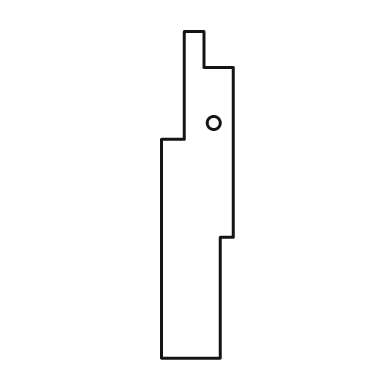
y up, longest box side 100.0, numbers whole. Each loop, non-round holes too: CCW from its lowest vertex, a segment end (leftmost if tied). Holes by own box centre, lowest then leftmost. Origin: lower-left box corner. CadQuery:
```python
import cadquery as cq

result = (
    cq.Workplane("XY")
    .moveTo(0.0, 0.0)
    .lineTo(18.0, 0.0)
    .lineTo(18.0, 37.0)
    .lineTo(22.0, 37.0)
    .lineTo(22.0, 89.0)
    .lineTo(13.0, 89.0)
    .lineTo(13.0, 100.0)
    .lineTo(7.0, 100.0)
    .lineTo(7.0, 67.0)
    .lineTo(0.0, 67.0)
    .close()
    .moveTo(16.0, 72.0)
    .circle(2.0)
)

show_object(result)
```